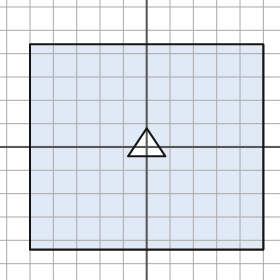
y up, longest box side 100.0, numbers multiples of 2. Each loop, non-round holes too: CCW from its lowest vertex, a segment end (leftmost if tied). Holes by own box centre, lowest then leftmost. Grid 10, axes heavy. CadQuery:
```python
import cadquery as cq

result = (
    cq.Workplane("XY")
    .moveTo(-50.0, -44.0)
    .lineTo(50.0, -44.0)
    .lineTo(50.0, 44.0)
    .lineTo(-50.0, 44.0)
    .close()
    .moveTo(-8.0, -4.0)
    .lineTo(8.0, -4.0)
    .lineTo(0.0, 8.0)
    .close()
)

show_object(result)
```